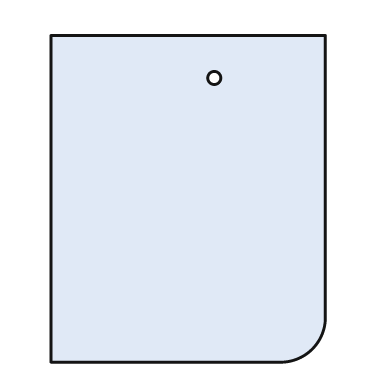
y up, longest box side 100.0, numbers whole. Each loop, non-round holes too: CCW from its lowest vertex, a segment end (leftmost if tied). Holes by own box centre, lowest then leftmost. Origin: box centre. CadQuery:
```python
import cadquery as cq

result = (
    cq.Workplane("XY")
    .moveTo(-42.0, -50.0)
    .lineTo(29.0, -50.0)
    .threePointArc((38.0, -46.0), (42.0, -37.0))
    .lineTo(42.0, 50.0)
    .lineTo(-42.0, 50.0)
    .close()
    .moveTo(8.0, 37.0)
    .circle(2.0)
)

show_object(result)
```